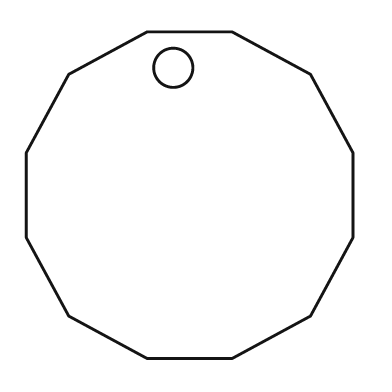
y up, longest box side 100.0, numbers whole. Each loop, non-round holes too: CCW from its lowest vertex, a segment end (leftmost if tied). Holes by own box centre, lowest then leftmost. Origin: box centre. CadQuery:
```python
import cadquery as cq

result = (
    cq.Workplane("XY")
    .moveTo(-13.0, -50.0)
    .lineTo(13.0, -50.0)
    .lineTo(37.0, -37.0)
    .lineTo(50.0, -13.0)
    .lineTo(50.0, 13.0)
    .lineTo(37.0, 37.0)
    .lineTo(13.0, 50.0)
    .lineTo(-13.0, 50.0)
    .lineTo(-37.0, 37.0)
    .lineTo(-50.0, 13.0)
    .lineTo(-50.0, -13.0)
    .lineTo(-37.0, -37.0)
    .close()
    .moveTo(-5.0, 39.0)
    .circle(6.0)
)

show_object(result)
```